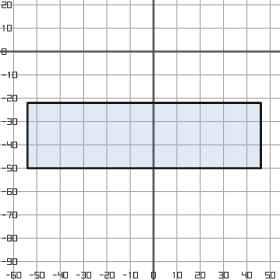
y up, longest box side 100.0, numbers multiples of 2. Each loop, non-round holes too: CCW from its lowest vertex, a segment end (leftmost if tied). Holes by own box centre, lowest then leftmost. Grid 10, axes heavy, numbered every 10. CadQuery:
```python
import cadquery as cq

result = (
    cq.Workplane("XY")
    .moveTo(-54.0, -50.0)
    .lineTo(46.0, -50.0)
    .lineTo(46.0, -22.0)
    .lineTo(-54.0, -22.0)
    .close()
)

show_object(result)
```